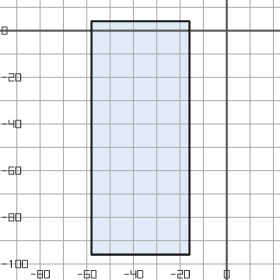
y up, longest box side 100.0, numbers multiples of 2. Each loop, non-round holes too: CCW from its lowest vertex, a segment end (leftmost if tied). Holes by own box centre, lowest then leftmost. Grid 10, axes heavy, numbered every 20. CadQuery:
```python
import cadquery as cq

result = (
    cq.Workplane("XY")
    .moveTo(-58.0, -96.0)
    .lineTo(-16.0, -96.0)
    .lineTo(-16.0, 4.0)
    .lineTo(-58.0, 4.0)
    .close()
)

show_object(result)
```